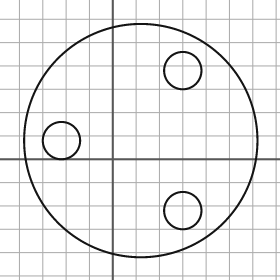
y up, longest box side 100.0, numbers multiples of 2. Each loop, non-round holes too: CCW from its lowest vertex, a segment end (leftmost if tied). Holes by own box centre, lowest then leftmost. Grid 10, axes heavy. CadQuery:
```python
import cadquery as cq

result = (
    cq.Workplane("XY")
    .moveTo(12.0, 8.0)
    .circle(50.0)
    .moveTo(30.0, -22.0)
    .circle(8.0)
    .moveTo(-22.0, 8.0)
    .circle(8.0)
    .moveTo(30.0, 38.0)
    .circle(8.0)
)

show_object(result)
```